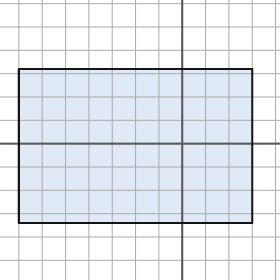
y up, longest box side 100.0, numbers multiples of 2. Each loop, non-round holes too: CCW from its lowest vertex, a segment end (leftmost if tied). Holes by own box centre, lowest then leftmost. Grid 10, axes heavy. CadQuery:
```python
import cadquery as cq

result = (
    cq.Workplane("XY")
    .moveTo(-70.0, -34.0)
    .lineTo(30.0, -34.0)
    .lineTo(30.0, 32.0)
    .lineTo(-70.0, 32.0)
    .close()
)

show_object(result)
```